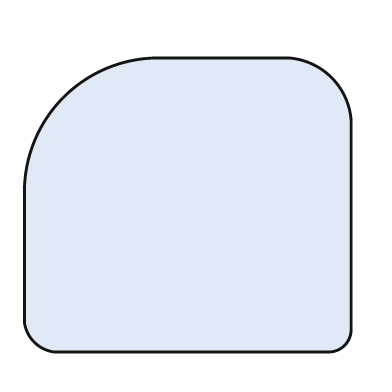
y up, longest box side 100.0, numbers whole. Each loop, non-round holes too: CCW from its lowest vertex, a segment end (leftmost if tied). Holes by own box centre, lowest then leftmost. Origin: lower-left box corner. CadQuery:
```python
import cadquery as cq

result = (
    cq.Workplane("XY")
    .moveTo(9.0, 0.0)
    .lineTo(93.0, 0.0)
    .threePointArc((98.0, 2.0), (100.0, 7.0))
    .lineTo(100.0, 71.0)
    .threePointArc((94.0, 84.0), (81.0, 90.0))
    .lineTo(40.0, 90.0)
    .threePointArc((12.0, 78.0), (0.0, 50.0))
    .lineTo(0.0, 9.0)
    .threePointArc((3.0, 3.0), (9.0, 0.0))
    .close()
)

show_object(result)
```